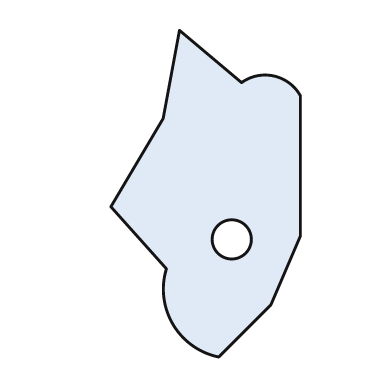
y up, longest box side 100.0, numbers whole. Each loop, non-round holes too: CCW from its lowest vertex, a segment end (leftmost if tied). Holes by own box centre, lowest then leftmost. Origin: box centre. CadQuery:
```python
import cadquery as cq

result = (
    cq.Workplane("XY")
    .moveTo(4.0, -50.0)
    .lineTo(20.0, -34.0)
    .lineTo(29.0, -13.0)
    .lineTo(29.0, 30.0)
    .threePointArc((21.0, 36.0), (11.0, 34.0))
    .lineTo(-8.0, 50.0)
    .lineTo(-13.0, 23.0)
    .lineTo(-29.0, -4.0)
    .lineTo(-12.0, -23.0)
    .threePointArc((-10.0, -40.0), (4.0, -50.0))
    .close()
    .moveTo(8.0, -14.0)
    .circle(6.0)
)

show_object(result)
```